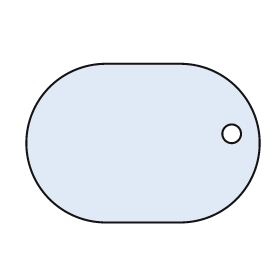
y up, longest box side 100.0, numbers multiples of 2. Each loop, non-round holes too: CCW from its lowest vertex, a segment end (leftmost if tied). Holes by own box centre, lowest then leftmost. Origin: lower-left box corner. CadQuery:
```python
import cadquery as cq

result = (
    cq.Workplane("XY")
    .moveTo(34.0, 0.0)
    .lineTo(66.0, 0.0)
    .threePointArc((100.0, 34.0), (66.0, 68.0))
    .lineTo(34.0, 68.0)
    .threePointArc((0.0, 34.0), (34.0, 0.0))
    .close()
    .moveTo(88.0, 38.0)
    .circle(4.0)
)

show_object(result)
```